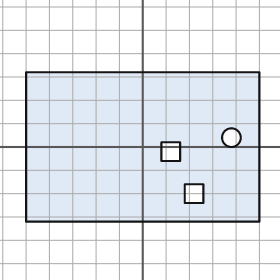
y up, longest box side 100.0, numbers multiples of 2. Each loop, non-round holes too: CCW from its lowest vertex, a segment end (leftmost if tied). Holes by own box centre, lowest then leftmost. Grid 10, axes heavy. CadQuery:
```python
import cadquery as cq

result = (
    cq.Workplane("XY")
    .moveTo(-50.0, -32.0)
    .lineTo(50.0, -32.0)
    .lineTo(50.0, 32.0)
    .lineTo(-50.0, 32.0)
    .close()
    .moveTo(18.0, -24.0)
    .lineTo(26.0, -24.0)
    .lineTo(26.0, -16.0)
    .lineTo(18.0, -16.0)
    .close()
    .moveTo(8.0, -6.0)
    .lineTo(16.0, -6.0)
    .lineTo(16.0, 2.0)
    .lineTo(8.0, 2.0)
    .close()
    .moveTo(38.0, 4.0)
    .circle(4.0)
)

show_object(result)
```